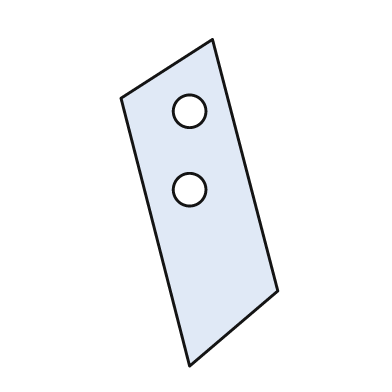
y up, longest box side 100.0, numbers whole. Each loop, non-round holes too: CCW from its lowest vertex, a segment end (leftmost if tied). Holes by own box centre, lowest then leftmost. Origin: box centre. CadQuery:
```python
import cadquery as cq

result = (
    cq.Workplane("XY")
    .moveTo(-3.0, -50.0)
    .lineTo(24.0, -27.0)
    .lineTo(4.0, 50.0)
    .lineTo(-24.0, 32.0)
    .close()
    .moveTo(-3.0, 4.0)
    .circle(5.0)
    .moveTo(-3.0, 28.0)
    .circle(5.0)
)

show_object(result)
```